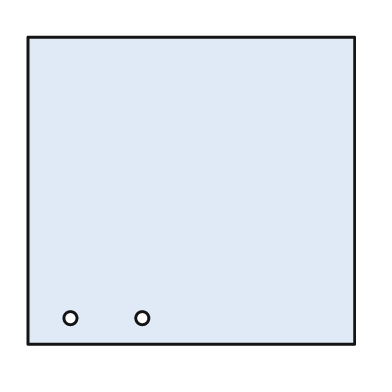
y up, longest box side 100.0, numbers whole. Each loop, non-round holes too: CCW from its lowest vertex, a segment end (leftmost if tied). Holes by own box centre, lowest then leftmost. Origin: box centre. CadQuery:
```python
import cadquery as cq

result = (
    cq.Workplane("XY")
    .moveTo(-50.0, -47.0)
    .lineTo(50.0, -47.0)
    .lineTo(50.0, 47.0)
    .lineTo(-50.0, 47.0)
    .close()
    .moveTo(-37.0, -39.0)
    .circle(2.0)
    .moveTo(-15.0, -39.0)
    .circle(2.0)
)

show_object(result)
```